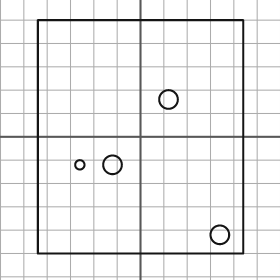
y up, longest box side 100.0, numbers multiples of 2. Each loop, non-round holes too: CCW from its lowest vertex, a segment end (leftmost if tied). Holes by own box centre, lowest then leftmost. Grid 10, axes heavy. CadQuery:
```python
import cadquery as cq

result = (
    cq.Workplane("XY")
    .moveTo(-44.0, -50.0)
    .lineTo(44.0, -50.0)
    .lineTo(44.0, 50.0)
    .lineTo(-44.0, 50.0)
    .close()
    .moveTo(34.0, -42.0)
    .circle(4.0)
    .moveTo(-26.0, -12.0)
    .circle(2.0)
    .moveTo(-12.0, -12.0)
    .circle(4.0)
    .moveTo(12.0, 16.0)
    .circle(4.0)
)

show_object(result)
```